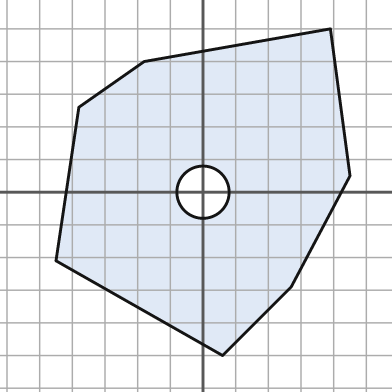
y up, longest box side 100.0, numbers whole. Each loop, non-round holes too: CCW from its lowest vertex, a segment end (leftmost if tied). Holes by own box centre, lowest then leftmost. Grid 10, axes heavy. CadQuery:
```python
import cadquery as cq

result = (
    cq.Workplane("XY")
    .moveTo(6.0, -50.0)
    .lineTo(27.0, -29.0)
    .lineTo(45.0, 5.0)
    .lineTo(39.0, 50.0)
    .lineTo(-18.0, 40.0)
    .lineTo(-38.0, 26.0)
    .lineTo(-45.0, -21.0)
    .close()
    .moveTo(0.0, 0.0)
    .circle(8.0)
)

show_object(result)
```